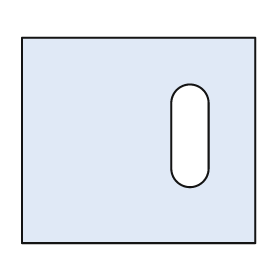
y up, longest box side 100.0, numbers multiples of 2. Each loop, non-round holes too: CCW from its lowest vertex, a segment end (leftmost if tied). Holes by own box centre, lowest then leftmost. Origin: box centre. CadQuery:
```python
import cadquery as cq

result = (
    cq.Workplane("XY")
    .moveTo(-50.0, -44.0)
    .lineTo(50.0, -44.0)
    .lineTo(50.0, 44.0)
    .lineTo(-50.0, 44.0)
    .close()
    .moveTo(14.0, -12.0)
    .threePointArc((22.0, -20.0), (30.0, -12.0))
    .lineTo(30.0, 16.0)
    .threePointArc((22.0, 24.0), (14.0, 16.0))
    .close()
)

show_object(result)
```